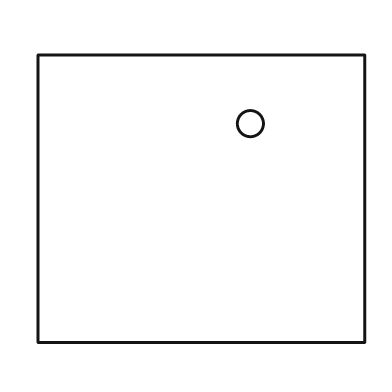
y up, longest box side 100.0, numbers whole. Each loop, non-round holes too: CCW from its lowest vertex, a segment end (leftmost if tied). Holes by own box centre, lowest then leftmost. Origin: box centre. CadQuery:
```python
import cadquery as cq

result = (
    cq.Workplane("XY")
    .moveTo(-50.0, -44.0)
    .lineTo(50.0, -44.0)
    .lineTo(50.0, 44.0)
    .lineTo(-50.0, 44.0)
    .close()
    .moveTo(15.0, 23.0)
    .circle(4.0)
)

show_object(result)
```